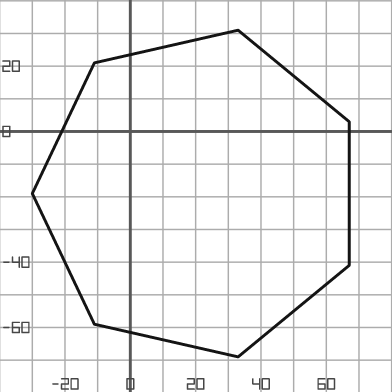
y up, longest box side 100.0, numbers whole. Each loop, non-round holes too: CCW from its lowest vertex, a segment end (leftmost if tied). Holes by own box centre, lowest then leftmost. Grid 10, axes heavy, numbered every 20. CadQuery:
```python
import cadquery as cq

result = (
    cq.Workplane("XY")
    .moveTo(33.0, -69.0)
    .lineTo(67.0, -41.0)
    .lineTo(67.0, 3.0)
    .lineTo(33.0, 31.0)
    .lineTo(-11.0, 21.0)
    .lineTo(-30.0, -19.0)
    .lineTo(-11.0, -59.0)
    .close()
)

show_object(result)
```